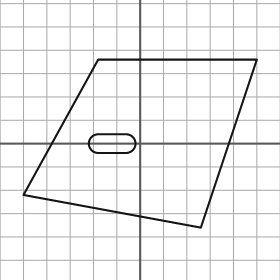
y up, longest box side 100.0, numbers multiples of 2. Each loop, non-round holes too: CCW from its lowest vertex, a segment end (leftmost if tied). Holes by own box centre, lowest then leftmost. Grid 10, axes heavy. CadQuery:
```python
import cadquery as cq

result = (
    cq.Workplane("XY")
    .moveTo(26.0, -36.0)
    .lineTo(50.0, 36.0)
    .lineTo(-18.0, 36.0)
    .lineTo(-50.0, -22.0)
    .close()
    .moveTo(-18.0, -4.0)
    .lineTo(-6.0, -4.0)
    .threePointArc((-2.0, 0.0), (-6.0, 4.0))
    .lineTo(-18.0, 4.0)
    .threePointArc((-22.0, 0.0), (-18.0, -4.0))
    .close()
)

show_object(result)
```